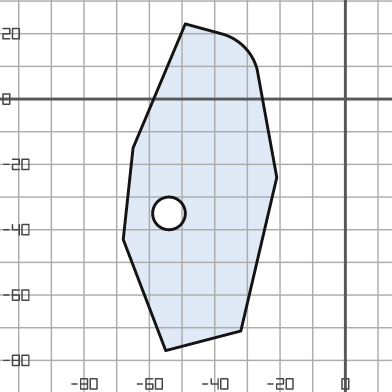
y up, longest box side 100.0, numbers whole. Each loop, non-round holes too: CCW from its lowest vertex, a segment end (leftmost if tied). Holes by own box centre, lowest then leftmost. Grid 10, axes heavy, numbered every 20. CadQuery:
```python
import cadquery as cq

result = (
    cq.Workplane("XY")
    .moveTo(-55.0, -77.0)
    .lineTo(-32.0, -71.0)
    .lineTo(-21.0, -24.0)
    .lineTo(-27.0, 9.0)
    .threePointArc((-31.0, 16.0), (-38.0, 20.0))
    .lineTo(-49.0, 23.0)
    .lineTo(-65.0, -15.0)
    .lineTo(-68.0, -43.0)
    .close()
    .moveTo(-54.0, -35.0)
    .circle(5.0)
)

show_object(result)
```